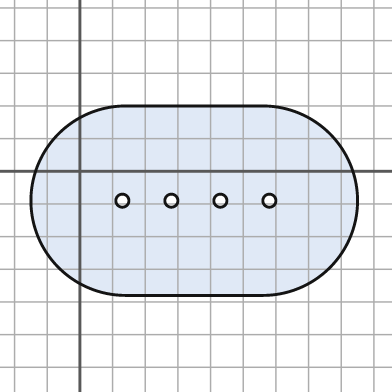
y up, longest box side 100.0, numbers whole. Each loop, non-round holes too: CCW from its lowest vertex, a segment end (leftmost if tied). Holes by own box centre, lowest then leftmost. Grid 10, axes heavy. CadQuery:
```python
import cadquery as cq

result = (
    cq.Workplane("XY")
    .moveTo(14.0, -38.0)
    .lineTo(56.0, -38.0)
    .threePointArc((85.0, -9.0), (56.0, 20.0))
    .lineTo(14.0, 20.0)
    .threePointArc((-15.0, -9.0), (14.0, -38.0))
    .close()
    .moveTo(13.0, -9.0)
    .circle(2.0)
    .moveTo(28.0, -9.0)
    .circle(2.0)
    .moveTo(43.0, -9.0)
    .circle(2.0)
    .moveTo(58.0, -9.0)
    .circle(2.0)
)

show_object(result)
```